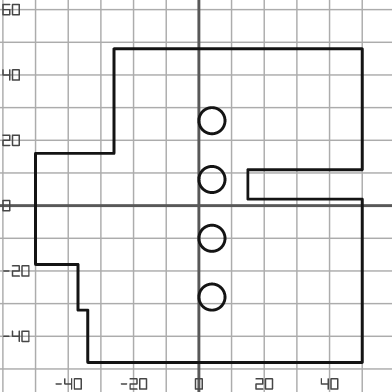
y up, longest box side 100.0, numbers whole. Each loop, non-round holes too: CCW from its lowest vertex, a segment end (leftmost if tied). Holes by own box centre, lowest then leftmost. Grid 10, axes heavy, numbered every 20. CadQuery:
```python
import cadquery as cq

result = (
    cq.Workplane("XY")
    .moveTo(-34.0, -48.0)
    .lineTo(50.0, -48.0)
    .lineTo(50.0, 2.0)
    .lineTo(15.0, 2.0)
    .lineTo(15.0, 11.0)
    .lineTo(50.0, 11.0)
    .lineTo(50.0, 48.0)
    .lineTo(-26.0, 48.0)
    .lineTo(-26.0, 16.0)
    .lineTo(-50.0, 16.0)
    .lineTo(-50.0, -18.0)
    .lineTo(-37.0, -18.0)
    .lineTo(-37.0, -32.0)
    .lineTo(-34.0, -32.0)
    .close()
    .moveTo(4.0, -28.0)
    .circle(4.0)
    .moveTo(4.0, -10.0)
    .circle(4.0)
    .moveTo(4.0, 8.0)
    .circle(4.0)
    .moveTo(4.0, 26.0)
    .circle(4.0)
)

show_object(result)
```